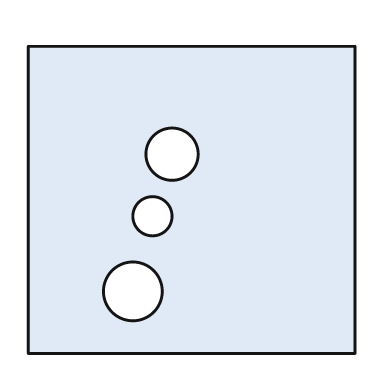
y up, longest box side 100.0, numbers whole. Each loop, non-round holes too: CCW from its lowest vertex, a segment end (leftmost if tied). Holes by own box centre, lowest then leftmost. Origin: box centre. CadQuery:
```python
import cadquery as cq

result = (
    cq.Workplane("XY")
    .moveTo(-50.0, -47.0)
    .lineTo(50.0, -47.0)
    .lineTo(50.0, 47.0)
    .lineTo(-50.0, 47.0)
    .close()
    .moveTo(-18.0, -28.0)
    .circle(9.0)
    .moveTo(-12.0, -5.0)
    .circle(6.0)
    .moveTo(-6.0, 14.0)
    .circle(8.0)
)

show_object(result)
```